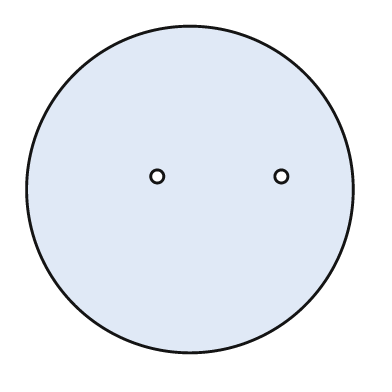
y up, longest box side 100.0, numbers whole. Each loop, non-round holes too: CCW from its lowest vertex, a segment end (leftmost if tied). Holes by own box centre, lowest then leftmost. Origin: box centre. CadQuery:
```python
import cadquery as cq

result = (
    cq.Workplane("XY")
    .moveTo(0.0, 0.0)
    .circle(50.0)
    .moveTo(-10.0, 4.0)
    .circle(2.0)
    .moveTo(28.0, 4.0)
    .circle(2.0)
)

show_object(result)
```